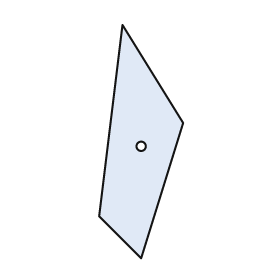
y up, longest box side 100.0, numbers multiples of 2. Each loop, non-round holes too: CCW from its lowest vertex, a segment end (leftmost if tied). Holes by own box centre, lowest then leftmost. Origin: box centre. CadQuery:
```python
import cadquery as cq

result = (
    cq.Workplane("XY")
    .moveTo(0.0, -50.0)
    .lineTo(18.0, 8.0)
    .lineTo(-8.0, 50.0)
    .lineTo(-18.0, -32.0)
    .close()
    .moveTo(0.0, -2.0)
    .circle(2.0)
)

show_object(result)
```